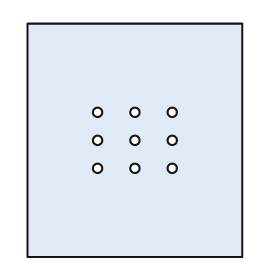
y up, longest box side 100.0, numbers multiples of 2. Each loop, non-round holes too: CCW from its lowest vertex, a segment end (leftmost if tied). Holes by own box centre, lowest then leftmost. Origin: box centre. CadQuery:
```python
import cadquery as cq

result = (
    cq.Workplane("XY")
    .moveTo(-46.0, -50.0)
    .lineTo(46.0, -50.0)
    .lineTo(46.0, 50.0)
    .lineTo(-46.0, 50.0)
    .close()
    .moveTo(-16.0, -12.0)
    .circle(2.0)
    .moveTo(0.0, -12.0)
    .circle(2.0)
    .moveTo(16.0, -12.0)
    .circle(2.0)
    .moveTo(-16.0, 0.0)
    .circle(2.0)
    .moveTo(0.0, 0.0)
    .circle(2.0)
    .moveTo(16.0, 0.0)
    .circle(2.0)
    .moveTo(-16.0, 12.0)
    .circle(2.0)
    .moveTo(0.0, 12.0)
    .circle(2.0)
    .moveTo(16.0, 12.0)
    .circle(2.0)
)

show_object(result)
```